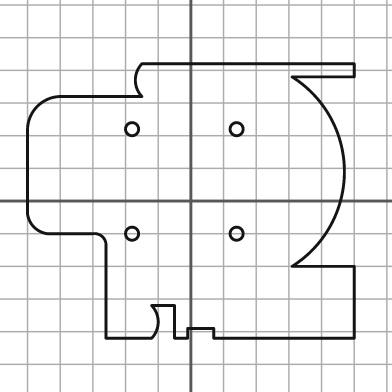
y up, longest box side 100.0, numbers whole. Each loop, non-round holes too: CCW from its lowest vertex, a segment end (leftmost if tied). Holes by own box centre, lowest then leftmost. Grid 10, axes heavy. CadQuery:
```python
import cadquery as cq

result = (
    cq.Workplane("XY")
    .moveTo(-26.0, -42.0)
    .lineTo(-12.0, -42.0)
    .threePointArc((-10.0, -37.0), (-12.0, -32.0))
    .lineTo(-5.0, -32.0)
    .lineTo(-5.0, -42.0)
    .lineTo(-1.0, -42.0)
    .lineTo(-1.0, -39.0)
    .lineTo(7.0, -39.0)
    .lineTo(7.0, -42.0)
    .lineTo(50.0, -42.0)
    .lineTo(50.0, -20.0)
    .lineTo(31.0, -20.0)
    .threePointArc((47.0, 9.0), (31.0, 38.0))
    .lineTo(50.0, 38.0)
    .lineTo(50.0, 42.0)
    .lineTo(-15.0, 42.0)
    .threePointArc((-17.0, 37.0), (-15.0, 32.0))
    .lineTo(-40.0, 32.0)
    .threePointArc((-47.0, 29.0), (-50.0, 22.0))
    .lineTo(-50.0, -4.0)
    .threePointArc((-48.0, -8.0), (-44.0, -10.0))
    .lineTo(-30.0, -10.0)
    .threePointArc((-27.0, -11.0), (-26.0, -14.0))
    .close()
    .moveTo(-18.0, -10.0)
    .circle(2.0)
    .moveTo(14.0, -10.0)
    .circle(2.0)
    .moveTo(-18.0, 22.0)
    .circle(2.0)
    .moveTo(14.0, 22.0)
    .circle(2.0)
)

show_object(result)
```